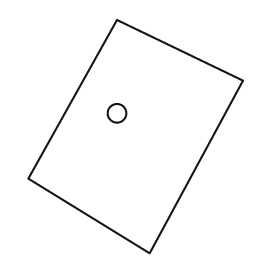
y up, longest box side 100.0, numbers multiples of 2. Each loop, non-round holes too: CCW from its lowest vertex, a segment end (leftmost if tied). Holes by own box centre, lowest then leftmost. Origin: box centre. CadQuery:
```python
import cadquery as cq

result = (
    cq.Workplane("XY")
    .moveTo(6.0, -50.0)
    .lineTo(46.0, 24.0)
    .lineTo(-8.0, 50.0)
    .lineTo(-46.0, -18.0)
    .close()
    .moveTo(-8.0, 10.0)
    .circle(4.0)
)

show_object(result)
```